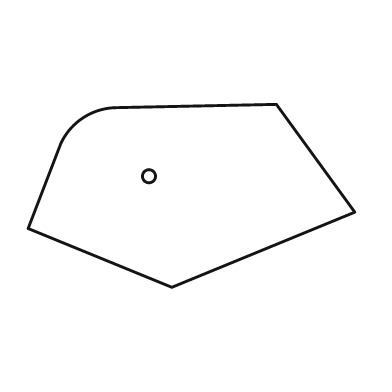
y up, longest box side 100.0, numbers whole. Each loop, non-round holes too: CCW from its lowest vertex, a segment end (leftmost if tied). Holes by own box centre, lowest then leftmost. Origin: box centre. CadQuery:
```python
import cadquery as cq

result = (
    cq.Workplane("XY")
    .moveTo(-6.0, -28.0)
    .lineTo(50.0, -5.0)
    .lineTo(26.0, 28.0)
    .lineTo(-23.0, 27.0)
    .threePointArc((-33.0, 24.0), (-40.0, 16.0))
    .lineTo(-50.0, -10.0)
    .close()
    .moveTo(-13.0, 6.0)
    .circle(2.0)
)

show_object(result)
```